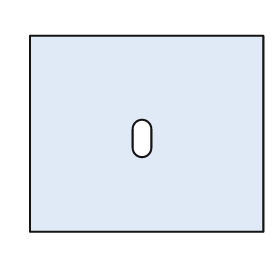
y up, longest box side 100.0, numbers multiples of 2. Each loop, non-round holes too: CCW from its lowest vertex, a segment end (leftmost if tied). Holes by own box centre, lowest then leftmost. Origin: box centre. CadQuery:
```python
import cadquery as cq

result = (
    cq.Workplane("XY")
    .moveTo(-50.0, -42.0)
    .lineTo(50.0, -42.0)
    .lineTo(50.0, 42.0)
    .lineTo(-50.0, 42.0)
    .close()
    .moveTo(-6.0, -6.0)
    .threePointArc((-2.0, -10.0), (2.0, -6.0))
    .lineTo(2.0, 2.0)
    .threePointArc((-2.0, 6.0), (-6.0, 2.0))
    .close()
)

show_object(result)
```